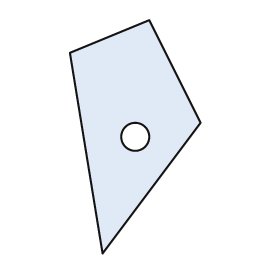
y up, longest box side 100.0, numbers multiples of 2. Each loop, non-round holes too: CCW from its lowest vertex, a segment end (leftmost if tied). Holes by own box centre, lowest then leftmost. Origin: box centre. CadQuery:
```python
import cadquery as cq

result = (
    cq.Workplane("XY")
    .moveTo(-14.0, -50.0)
    .lineTo(28.0, 6.0)
    .lineTo(6.0, 50.0)
    .lineTo(-28.0, 36.0)
    .close()
    .moveTo(0.0, 0.0)
    .circle(6.0)
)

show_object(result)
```